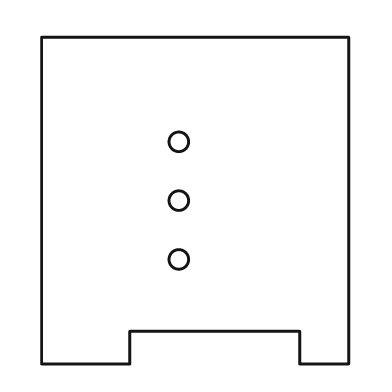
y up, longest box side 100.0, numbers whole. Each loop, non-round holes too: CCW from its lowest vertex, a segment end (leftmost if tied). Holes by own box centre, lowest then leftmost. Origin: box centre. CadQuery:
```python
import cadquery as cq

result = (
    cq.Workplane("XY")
    .moveTo(-47.0, -50.0)
    .lineTo(-20.0, -50.0)
    .lineTo(-20.0, -40.0)
    .lineTo(32.0, -40.0)
    .lineTo(32.0, -50.0)
    .lineTo(47.0, -50.0)
    .lineTo(47.0, 50.0)
    .lineTo(-47.0, 50.0)
    .close()
    .moveTo(-5.0, -18.0)
    .circle(3.0)
    .moveTo(-5.0, 0.0)
    .circle(3.0)
    .moveTo(-5.0, 18.0)
    .circle(3.0)
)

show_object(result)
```